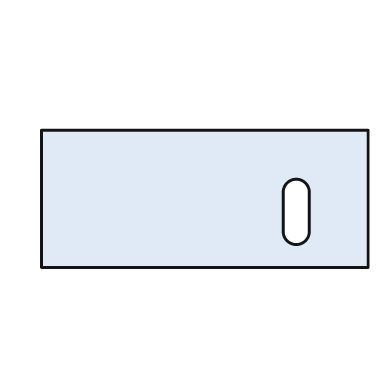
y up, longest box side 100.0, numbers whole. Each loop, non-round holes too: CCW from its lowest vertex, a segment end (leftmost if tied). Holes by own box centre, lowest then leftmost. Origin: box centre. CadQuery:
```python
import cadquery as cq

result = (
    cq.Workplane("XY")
    .moveTo(-50.0, -21.0)
    .lineTo(50.0, -21.0)
    .lineTo(50.0, 21.0)
    .lineTo(-50.0, 21.0)
    .close()
    .moveTo(24.0, -10.0)
    .threePointArc((28.0, -14.0), (32.0, -10.0))
    .lineTo(32.0, 2.0)
    .threePointArc((28.0, 6.0), (24.0, 2.0))
    .close()
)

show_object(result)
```